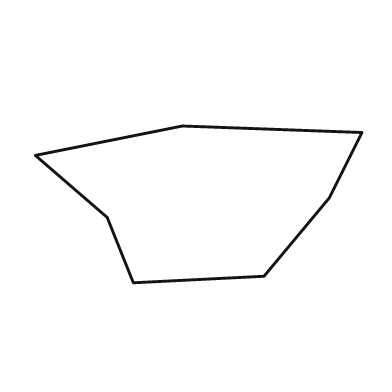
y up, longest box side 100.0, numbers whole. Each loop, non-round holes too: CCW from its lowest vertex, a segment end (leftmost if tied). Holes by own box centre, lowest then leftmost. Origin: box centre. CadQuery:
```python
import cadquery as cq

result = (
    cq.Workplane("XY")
    .moveTo(-20.0, -24.0)
    .lineTo(20.0, -22.0)
    .lineTo(40.0, 2.0)
    .lineTo(50.0, 22.0)
    .lineTo(-5.0, 24.0)
    .lineTo(-50.0, 15.0)
    .lineTo(-28.0, -4.0)
    .close()
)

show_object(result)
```